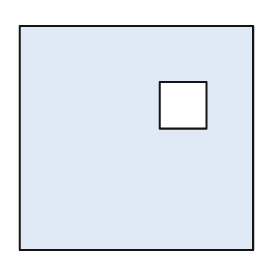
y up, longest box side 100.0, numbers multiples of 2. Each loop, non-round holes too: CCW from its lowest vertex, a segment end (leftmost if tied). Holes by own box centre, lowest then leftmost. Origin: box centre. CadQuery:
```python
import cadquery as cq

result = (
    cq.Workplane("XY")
    .moveTo(-50.0, -48.0)
    .lineTo(50.0, -48.0)
    .lineTo(50.0, 48.0)
    .lineTo(-50.0, 48.0)
    .close()
    .moveTo(10.0, 4.0)
    .lineTo(30.0, 4.0)
    .lineTo(30.0, 24.0)
    .lineTo(10.0, 24.0)
    .close()
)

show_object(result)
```